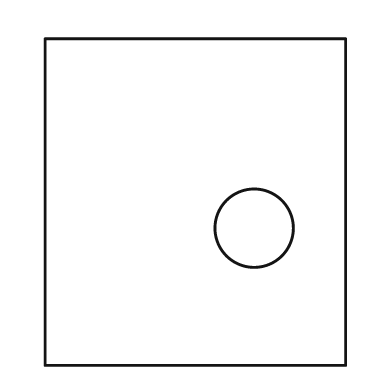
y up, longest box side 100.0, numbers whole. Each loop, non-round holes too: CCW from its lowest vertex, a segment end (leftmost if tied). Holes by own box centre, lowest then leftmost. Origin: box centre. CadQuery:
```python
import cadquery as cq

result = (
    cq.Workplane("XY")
    .moveTo(-46.0, -50.0)
    .lineTo(46.0, -50.0)
    .lineTo(46.0, 50.0)
    .lineTo(-46.0, 50.0)
    .close()
    .moveTo(18.0, -8.0)
    .circle(12.0)
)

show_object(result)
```